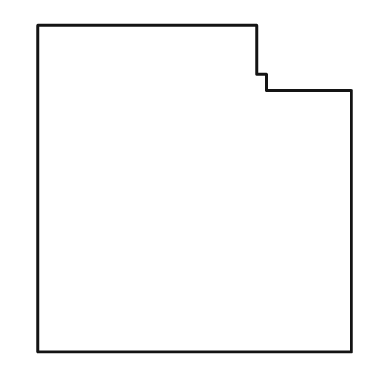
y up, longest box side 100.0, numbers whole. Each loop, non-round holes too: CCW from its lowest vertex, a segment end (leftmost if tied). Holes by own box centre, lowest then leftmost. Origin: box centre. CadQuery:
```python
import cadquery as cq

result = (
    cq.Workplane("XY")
    .moveTo(-48.0, -50.0)
    .lineTo(48.0, -50.0)
    .lineTo(48.0, 30.0)
    .lineTo(22.0, 30.0)
    .lineTo(22.0, 35.0)
    .lineTo(19.0, 35.0)
    .lineTo(19.0, 50.0)
    .lineTo(-48.0, 50.0)
    .close()
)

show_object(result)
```